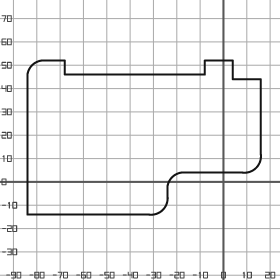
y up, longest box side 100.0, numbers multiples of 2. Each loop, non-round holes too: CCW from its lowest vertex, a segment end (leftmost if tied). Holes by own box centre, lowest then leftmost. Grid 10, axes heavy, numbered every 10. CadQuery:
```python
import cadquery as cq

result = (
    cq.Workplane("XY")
    .moveTo(-84.0, -14.0)
    .lineTo(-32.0, -14.0)
    .threePointArc((-26.0, -12.0), (-24.0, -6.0))
    .lineTo(-24.0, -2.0)
    .threePointArc((-22.0, 2.0), (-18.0, 4.0))
    .lineTo(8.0, 4.0)
    .threePointArc((14.0, 6.0), (16.0, 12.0))
    .lineTo(16.0, 44.0)
    .lineTo(4.0, 44.0)
    .lineTo(4.0, 52.0)
    .lineTo(-8.0, 52.0)
    .lineTo(-8.0, 46.0)
    .lineTo(-68.0, 46.0)
    .lineTo(-68.0, 52.0)
    .lineTo(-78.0, 52.0)
    .threePointArc((-82.0, 50.0), (-84.0, 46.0))
    .close()
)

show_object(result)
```